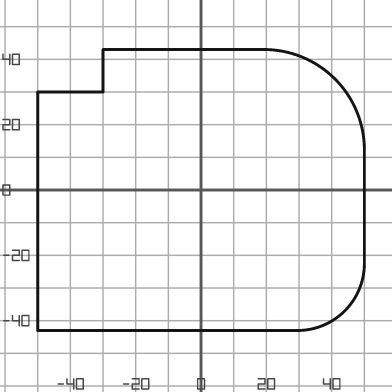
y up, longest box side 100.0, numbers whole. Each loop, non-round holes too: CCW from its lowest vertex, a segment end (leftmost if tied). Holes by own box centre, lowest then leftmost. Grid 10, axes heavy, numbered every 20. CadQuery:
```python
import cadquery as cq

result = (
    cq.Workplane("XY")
    .moveTo(-50.0, -43.0)
    .lineTo(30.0, -43.0)
    .threePointArc((44.0, -37.0), (50.0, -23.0))
    .lineTo(50.0, 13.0)
    .threePointArc((41.0, 34.0), (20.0, 43.0))
    .lineTo(-30.0, 43.0)
    .lineTo(-30.0, 30.0)
    .lineTo(-50.0, 30.0)
    .close()
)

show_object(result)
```